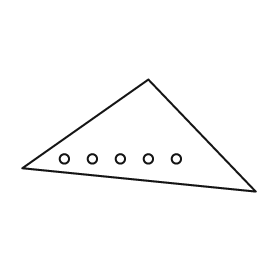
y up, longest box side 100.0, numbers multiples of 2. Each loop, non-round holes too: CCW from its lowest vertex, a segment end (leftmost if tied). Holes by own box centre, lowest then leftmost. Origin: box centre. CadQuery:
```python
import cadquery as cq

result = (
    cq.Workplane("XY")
    .moveTo(50.0, -24.0)
    .lineTo(4.0, 24.0)
    .lineTo(-50.0, -14.0)
    .close()
    .moveTo(-32.0, -10.0)
    .circle(2.0)
    .moveTo(-20.0, -10.0)
    .circle(2.0)
    .moveTo(-8.0, -10.0)
    .circle(2.0)
    .moveTo(4.0, -10.0)
    .circle(2.0)
    .moveTo(16.0, -10.0)
    .circle(2.0)
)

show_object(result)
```